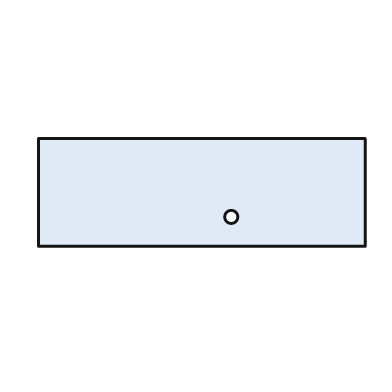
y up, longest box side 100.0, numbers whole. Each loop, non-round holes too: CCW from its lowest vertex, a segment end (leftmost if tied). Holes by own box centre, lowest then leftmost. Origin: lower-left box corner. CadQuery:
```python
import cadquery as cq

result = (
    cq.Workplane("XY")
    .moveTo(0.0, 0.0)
    .lineTo(100.0, 0.0)
    .lineTo(100.0, 33.0)
    .lineTo(0.0, 33.0)
    .close()
    .moveTo(59.0, 9.0)
    .circle(2.0)
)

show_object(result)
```